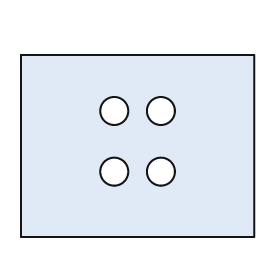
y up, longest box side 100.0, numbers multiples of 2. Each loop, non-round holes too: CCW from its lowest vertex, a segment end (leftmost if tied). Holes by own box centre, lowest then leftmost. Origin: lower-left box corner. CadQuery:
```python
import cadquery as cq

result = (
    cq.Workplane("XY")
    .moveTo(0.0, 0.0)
    .lineTo(100.0, 0.0)
    .lineTo(100.0, 78.0)
    .lineTo(0.0, 78.0)
    .close()
    .moveTo(40.0, 28.0)
    .circle(6.0)
    .moveTo(60.0, 28.0)
    .circle(6.0)
    .moveTo(40.0, 54.0)
    .circle(6.0)
    .moveTo(60.0, 54.0)
    .circle(6.0)
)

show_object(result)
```